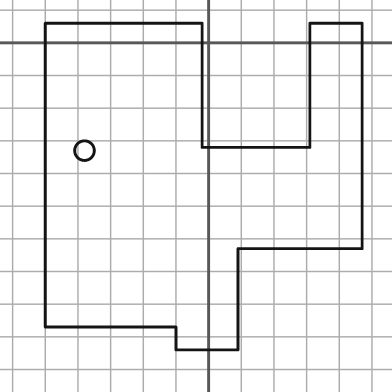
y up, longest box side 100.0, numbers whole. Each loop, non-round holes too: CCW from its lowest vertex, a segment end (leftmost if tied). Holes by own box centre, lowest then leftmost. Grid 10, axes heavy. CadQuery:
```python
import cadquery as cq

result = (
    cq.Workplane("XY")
    .moveTo(-10.0, -94.0)
    .lineTo(9.0, -94.0)
    .lineTo(9.0, -63.0)
    .lineTo(47.0, -63.0)
    .lineTo(47.0, 6.0)
    .lineTo(31.0, 6.0)
    .lineTo(31.0, -32.0)
    .lineTo(-2.0, -32.0)
    .lineTo(-2.0, 6.0)
    .lineTo(-50.0, 6.0)
    .lineTo(-50.0, -87.0)
    .lineTo(-10.0, -87.0)
    .close()
    .moveTo(-38.0, -33.0)
    .circle(3.0)
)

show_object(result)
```